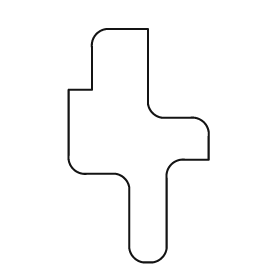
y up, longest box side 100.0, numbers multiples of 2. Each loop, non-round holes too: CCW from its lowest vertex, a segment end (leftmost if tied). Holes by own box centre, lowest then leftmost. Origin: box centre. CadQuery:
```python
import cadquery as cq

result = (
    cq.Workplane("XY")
    .moveTo(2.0, -50.0)
    .lineTo(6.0, -50.0)
    .threePointArc((10.0, -48.0), (12.0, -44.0))
    .lineTo(12.0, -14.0)
    .threePointArc((14.0, -8.0), (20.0, -6.0))
    .lineTo(30.0, -6.0)
    .lineTo(30.0, 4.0)
    .threePointArc((28.0, 10.0), (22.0, 12.0))
    .lineTo(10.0, 12.0)
    .threePointArc((6.0, 14.0), (4.0, 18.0))
    .lineTo(4.0, 50.0)
    .lineTo(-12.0, 50.0)
    .threePointArc((-18.0, 48.0), (-20.0, 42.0))
    .lineTo(-20.0, 24.0)
    .lineTo(-30.0, 24.0)
    .lineTo(-30.0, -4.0)
    .threePointArc((-28.0, -10.0), (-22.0, -12.0))
    .lineTo(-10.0, -12.0)
    .threePointArc((-6.0, -14.0), (-4.0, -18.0))
    .lineTo(-4.0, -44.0)
    .threePointArc((-2.0, -48.0), (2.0, -50.0))
    .close()
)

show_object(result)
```